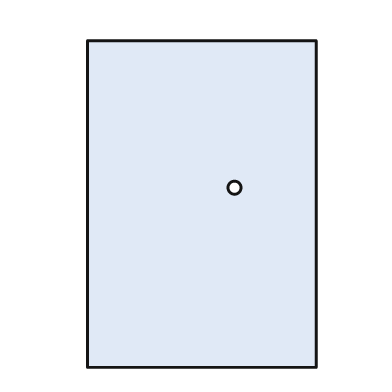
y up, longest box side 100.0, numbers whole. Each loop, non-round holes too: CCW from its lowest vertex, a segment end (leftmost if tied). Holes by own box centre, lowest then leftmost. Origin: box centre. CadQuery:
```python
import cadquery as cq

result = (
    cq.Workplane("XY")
    .moveTo(-35.0, -50.0)
    .lineTo(35.0, -50.0)
    .lineTo(35.0, 50.0)
    .lineTo(-35.0, 50.0)
    .close()
    .moveTo(10.0, 5.0)
    .circle(2.0)
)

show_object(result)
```